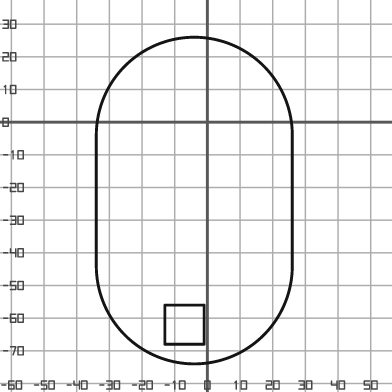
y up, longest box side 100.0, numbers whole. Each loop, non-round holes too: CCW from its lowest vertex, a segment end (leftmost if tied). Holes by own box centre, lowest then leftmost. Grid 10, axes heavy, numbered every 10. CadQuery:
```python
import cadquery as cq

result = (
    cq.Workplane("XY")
    .moveTo(-34.0, -44.0)
    .threePointArc((-4.0, -74.0), (26.0, -44.0))
    .lineTo(26.0, -4.0)
    .threePointArc((-4.0, 26.0), (-34.0, -4.0))
    .close()
    .moveTo(-13.0, -68.0)
    .lineTo(-1.0, -68.0)
    .lineTo(-1.0, -56.0)
    .lineTo(-13.0, -56.0)
    .close()
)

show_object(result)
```